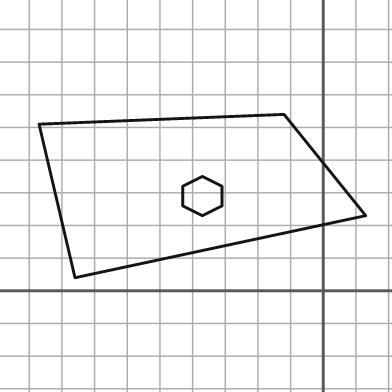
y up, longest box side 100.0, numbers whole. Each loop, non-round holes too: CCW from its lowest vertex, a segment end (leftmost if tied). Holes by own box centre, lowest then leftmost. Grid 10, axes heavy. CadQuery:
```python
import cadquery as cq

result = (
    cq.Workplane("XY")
    .moveTo(-76.0, 4.0)
    .lineTo(13.0, 23.0)
    .lineTo(-12.0, 54.0)
    .lineTo(-87.0, 51.0)
    .close()
    .moveTo(-37.0, 23.0)
    .lineTo(-31.0, 26.0)
    .lineTo(-31.0, 32.0)
    .lineTo(-37.0, 35.0)
    .lineTo(-43.0, 32.0)
    .lineTo(-43.0, 26.0)
    .close()
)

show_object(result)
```